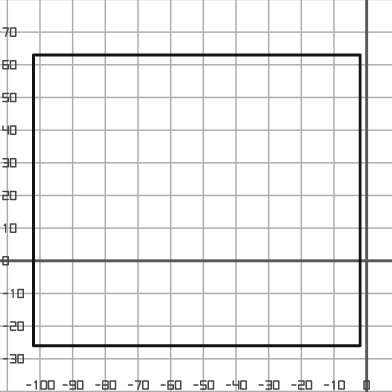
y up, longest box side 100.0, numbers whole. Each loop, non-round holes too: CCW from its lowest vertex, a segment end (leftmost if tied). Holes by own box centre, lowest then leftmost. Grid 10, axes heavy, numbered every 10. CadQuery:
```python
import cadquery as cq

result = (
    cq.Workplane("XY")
    .moveTo(-102.0, -26.0)
    .lineTo(-2.0, -26.0)
    .lineTo(-2.0, 63.0)
    .lineTo(-102.0, 63.0)
    .close()
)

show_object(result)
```